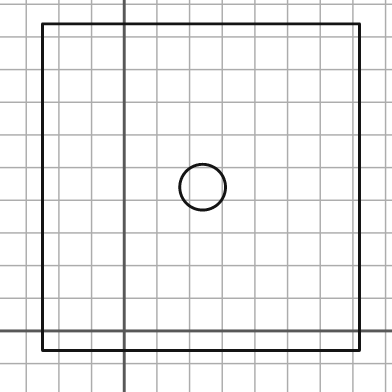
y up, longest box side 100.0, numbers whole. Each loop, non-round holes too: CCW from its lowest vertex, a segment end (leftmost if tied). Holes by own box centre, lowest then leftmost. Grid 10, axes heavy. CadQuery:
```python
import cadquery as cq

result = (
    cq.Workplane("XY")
    .moveTo(-25.0, -6.0)
    .lineTo(72.0, -6.0)
    .lineTo(72.0, 94.0)
    .lineTo(-25.0, 94.0)
    .close()
    .moveTo(24.0, 44.0)
    .circle(7.0)
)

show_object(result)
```